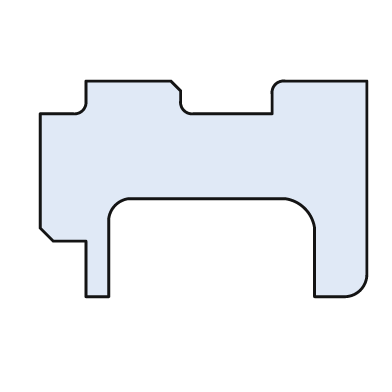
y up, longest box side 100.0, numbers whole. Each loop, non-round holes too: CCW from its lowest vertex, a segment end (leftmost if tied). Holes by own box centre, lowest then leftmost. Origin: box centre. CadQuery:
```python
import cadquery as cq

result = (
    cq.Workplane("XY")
    .moveTo(-36.0, -33.0)
    .lineTo(-29.0, -33.0)
    .lineTo(-29.0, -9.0)
    .threePointArc((-27.0, -5.0), (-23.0, -3.0))
    .lineTo(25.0, -3.0)
    .threePointArc((31.0, -6.0), (34.0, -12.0))
    .lineTo(34.0, -33.0)
    .lineTo(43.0, -33.0)
    .threePointArc((48.0, -31.0), (50.0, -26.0))
    .lineTo(50.0, 33.0)
    .lineTo(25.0, 33.0)
    .threePointArc((22.0, 32.0), (21.0, 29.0))
    .lineTo(21.0, 23.0)
    .lineTo(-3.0, 23.0)
    .threePointArc((-6.0, 24.0), (-7.0, 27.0))
    .lineTo(-7.0, 30.0)
    .lineTo(-10.0, 33.0)
    .lineTo(-36.0, 33.0)
    .lineTo(-36.0, 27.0)
    .threePointArc((-37.0, 24.0), (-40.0, 23.0))
    .lineTo(-50.0, 23.0)
    .lineTo(-50.0, -12.0)
    .lineTo(-46.0, -16.0)
    .lineTo(-36.0, -16.0)
    .close()
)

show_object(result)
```